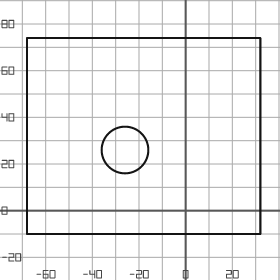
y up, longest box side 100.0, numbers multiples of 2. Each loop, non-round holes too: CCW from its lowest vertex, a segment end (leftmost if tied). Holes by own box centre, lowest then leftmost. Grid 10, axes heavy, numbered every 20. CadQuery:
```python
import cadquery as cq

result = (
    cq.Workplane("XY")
    .moveTo(-68.0, -10.0)
    .lineTo(32.0, -10.0)
    .lineTo(32.0, 74.0)
    .lineTo(-68.0, 74.0)
    .close()
    .moveTo(-26.0, 26.0)
    .circle(10.0)
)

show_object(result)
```